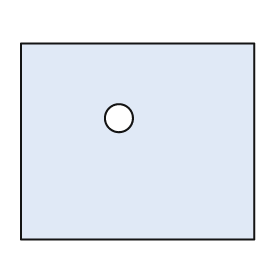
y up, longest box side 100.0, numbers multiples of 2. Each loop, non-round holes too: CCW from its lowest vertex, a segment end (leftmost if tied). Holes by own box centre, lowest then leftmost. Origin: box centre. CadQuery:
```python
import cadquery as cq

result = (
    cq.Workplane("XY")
    .moveTo(-50.0, -42.0)
    .lineTo(50.0, -42.0)
    .lineTo(50.0, 42.0)
    .lineTo(-50.0, 42.0)
    .close()
    .moveTo(-8.0, 10.0)
    .circle(6.0)
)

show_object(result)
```